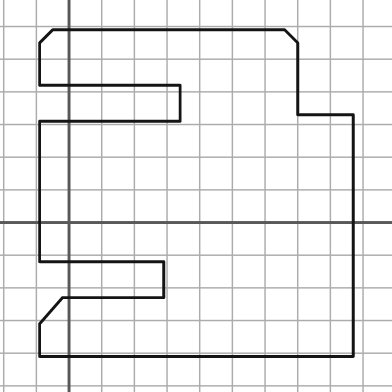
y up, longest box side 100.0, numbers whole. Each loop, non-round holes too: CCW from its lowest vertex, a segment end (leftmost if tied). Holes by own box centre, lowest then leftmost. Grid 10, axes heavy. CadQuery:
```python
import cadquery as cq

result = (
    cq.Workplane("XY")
    .moveTo(-9.0, -41.0)
    .lineTo(87.0, -41.0)
    .lineTo(87.0, 33.0)
    .lineTo(70.0, 33.0)
    .lineTo(70.0, 55.0)
    .lineTo(66.0, 59.0)
    .lineTo(-5.0, 59.0)
    .lineTo(-9.0, 55.0)
    .lineTo(-9.0, 42.0)
    .lineTo(34.0, 42.0)
    .lineTo(34.0, 31.0)
    .lineTo(-9.0, 31.0)
    .lineTo(-9.0, -12.0)
    .lineTo(29.0, -12.0)
    .lineTo(29.0, -23.0)
    .lineTo(-2.0, -23.0)
    .lineTo(-9.0, -31.0)
    .close()
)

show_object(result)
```